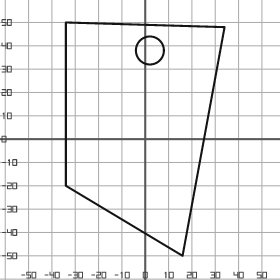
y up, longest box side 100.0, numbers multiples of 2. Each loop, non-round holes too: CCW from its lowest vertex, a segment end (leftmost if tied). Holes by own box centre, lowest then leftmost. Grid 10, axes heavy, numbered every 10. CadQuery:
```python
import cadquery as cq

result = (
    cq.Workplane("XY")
    .moveTo(16.0, -50.0)
    .lineTo(34.0, 48.0)
    .lineTo(-34.0, 50.0)
    .lineTo(-34.0, -20.0)
    .close()
    .moveTo(2.0, 38.0)
    .circle(6.0)
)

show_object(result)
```